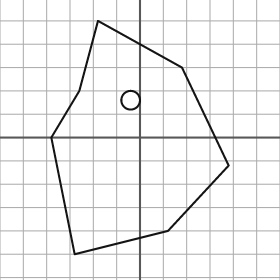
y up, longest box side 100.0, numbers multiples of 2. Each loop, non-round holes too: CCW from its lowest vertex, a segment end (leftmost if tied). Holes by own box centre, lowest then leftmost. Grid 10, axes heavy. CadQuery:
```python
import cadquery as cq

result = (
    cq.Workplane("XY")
    .moveTo(-28.0, -50.0)
    .lineTo(12.0, -40.0)
    .lineTo(38.0, -12.0)
    .lineTo(18.0, 30.0)
    .lineTo(-18.0, 50.0)
    .lineTo(-26.0, 20.0)
    .lineTo(-38.0, 0.0)
    .close()
    .moveTo(-4.0, 16.0)
    .circle(4.0)
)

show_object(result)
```